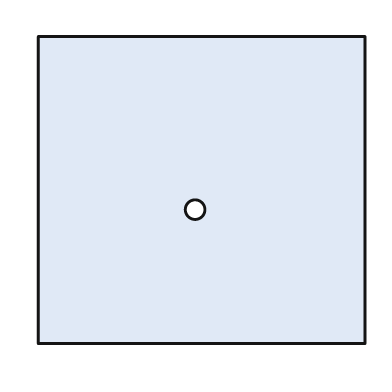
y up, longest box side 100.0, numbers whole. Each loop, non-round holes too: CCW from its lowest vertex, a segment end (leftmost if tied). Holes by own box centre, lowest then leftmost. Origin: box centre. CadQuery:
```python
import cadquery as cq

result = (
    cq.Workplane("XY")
    .moveTo(-50.0, -47.0)
    .lineTo(50.0, -47.0)
    .lineTo(50.0, 47.0)
    .lineTo(-50.0, 47.0)
    .close()
    .moveTo(-2.0, -6.0)
    .circle(3.0)
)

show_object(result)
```